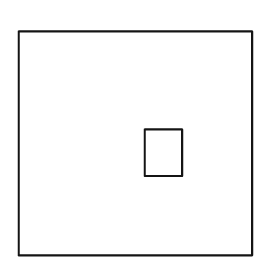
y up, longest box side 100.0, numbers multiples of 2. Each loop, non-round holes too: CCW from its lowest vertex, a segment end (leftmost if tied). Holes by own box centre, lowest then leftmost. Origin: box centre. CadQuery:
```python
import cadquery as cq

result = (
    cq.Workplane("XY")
    .moveTo(-50.0, -48.0)
    .lineTo(50.0, -48.0)
    .lineTo(50.0, 48.0)
    .lineTo(-50.0, 48.0)
    .close()
    .moveTo(4.0, -14.0)
    .lineTo(20.0, -14.0)
    .lineTo(20.0, 6.0)
    .lineTo(4.0, 6.0)
    .close()
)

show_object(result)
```